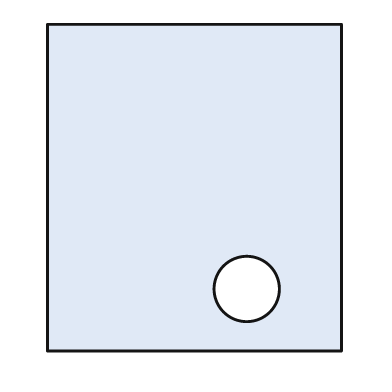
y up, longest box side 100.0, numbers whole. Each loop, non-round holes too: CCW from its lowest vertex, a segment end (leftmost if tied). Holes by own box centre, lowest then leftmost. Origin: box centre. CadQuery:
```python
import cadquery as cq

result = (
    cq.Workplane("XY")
    .moveTo(-45.0, -50.0)
    .lineTo(45.0, -50.0)
    .lineTo(45.0, 50.0)
    .lineTo(-45.0, 50.0)
    .close()
    .moveTo(16.0, -31.0)
    .circle(10.0)
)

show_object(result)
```